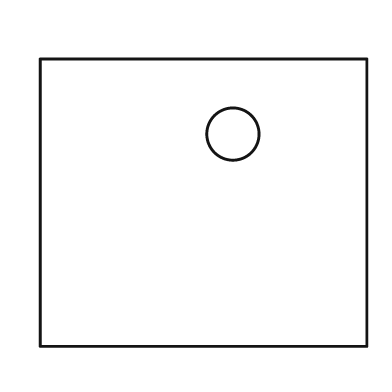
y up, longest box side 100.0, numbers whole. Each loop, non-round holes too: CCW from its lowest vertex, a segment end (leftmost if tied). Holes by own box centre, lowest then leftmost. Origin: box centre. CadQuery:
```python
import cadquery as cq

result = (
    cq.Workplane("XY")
    .moveTo(-50.0, -44.0)
    .lineTo(50.0, -44.0)
    .lineTo(50.0, 44.0)
    .lineTo(-50.0, 44.0)
    .close()
    .moveTo(9.0, 21.0)
    .circle(8.0)
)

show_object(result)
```